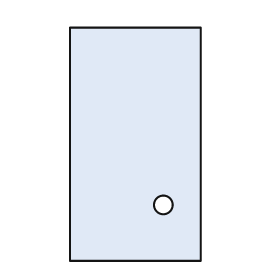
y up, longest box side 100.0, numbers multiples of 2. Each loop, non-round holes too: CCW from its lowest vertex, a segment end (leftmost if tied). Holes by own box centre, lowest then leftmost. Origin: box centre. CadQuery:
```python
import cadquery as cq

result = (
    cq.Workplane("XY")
    .moveTo(-28.0, -50.0)
    .lineTo(28.0, -50.0)
    .lineTo(28.0, 50.0)
    .lineTo(-28.0, 50.0)
    .close()
    .moveTo(12.0, -26.0)
    .circle(4.0)
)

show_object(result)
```